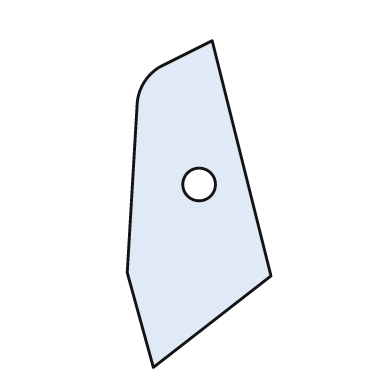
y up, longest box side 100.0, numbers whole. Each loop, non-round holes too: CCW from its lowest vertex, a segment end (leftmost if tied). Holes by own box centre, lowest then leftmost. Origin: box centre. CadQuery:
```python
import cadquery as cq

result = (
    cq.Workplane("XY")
    .moveTo(-14.0, -50.0)
    .lineTo(22.0, -22.0)
    .lineTo(4.0, 50.0)
    .lineTo(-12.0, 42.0)
    .threePointArc((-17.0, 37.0), (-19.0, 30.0))
    .lineTo(-22.0, -21.0)
    .close()
    .moveTo(0.0, 6.0)
    .circle(5.0)
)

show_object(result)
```